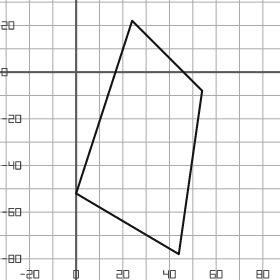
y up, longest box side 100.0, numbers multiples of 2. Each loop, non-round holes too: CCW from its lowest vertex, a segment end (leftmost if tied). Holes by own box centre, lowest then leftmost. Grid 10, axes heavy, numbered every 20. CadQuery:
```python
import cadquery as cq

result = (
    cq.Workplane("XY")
    .moveTo(44.0, -78.0)
    .lineTo(54.0, -8.0)
    .lineTo(24.0, 22.0)
    .lineTo(0.0, -52.0)
    .close()
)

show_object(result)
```